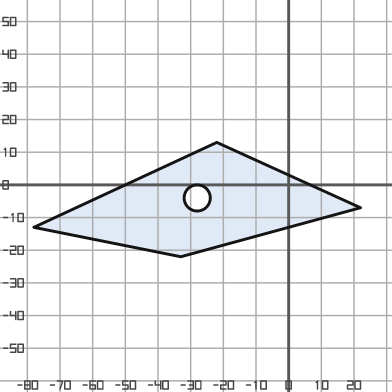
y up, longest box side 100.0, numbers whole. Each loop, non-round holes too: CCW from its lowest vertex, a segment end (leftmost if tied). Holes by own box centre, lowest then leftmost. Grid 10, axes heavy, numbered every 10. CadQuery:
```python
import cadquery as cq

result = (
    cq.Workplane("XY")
    .moveTo(-33.0, -22.0)
    .lineTo(22.0, -7.0)
    .lineTo(-22.0, 13.0)
    .lineTo(-78.0, -13.0)
    .close()
    .moveTo(-28.0, -4.0)
    .circle(4.0)
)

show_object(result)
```